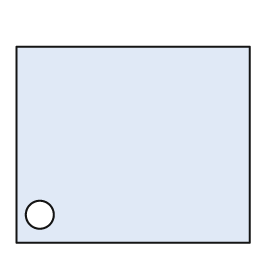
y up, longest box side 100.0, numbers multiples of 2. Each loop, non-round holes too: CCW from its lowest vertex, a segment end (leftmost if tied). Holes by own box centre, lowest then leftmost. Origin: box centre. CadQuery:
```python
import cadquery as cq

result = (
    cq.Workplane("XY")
    .moveTo(-50.0, -42.0)
    .lineTo(50.0, -42.0)
    .lineTo(50.0, 42.0)
    .lineTo(-50.0, 42.0)
    .close()
    .moveTo(-40.0, -30.0)
    .circle(6.0)
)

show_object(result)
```